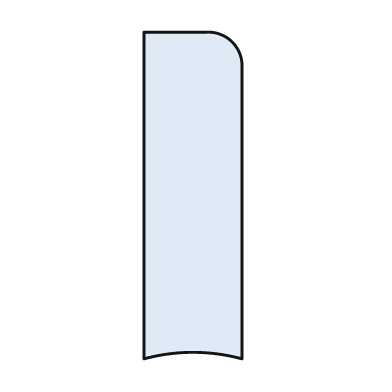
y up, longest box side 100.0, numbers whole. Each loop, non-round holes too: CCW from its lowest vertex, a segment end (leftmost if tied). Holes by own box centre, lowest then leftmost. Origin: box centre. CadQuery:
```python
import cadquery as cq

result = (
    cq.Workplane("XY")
    .moveTo(-15.0, -50.0)
    .threePointArc((0.0, -48.0), (15.0, -50.0))
    .lineTo(15.0, 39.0)
    .threePointArc((12.0, 47.0), (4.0, 50.0))
    .lineTo(-15.0, 50.0)
    .close()
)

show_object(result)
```